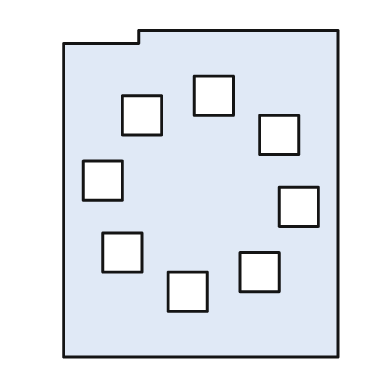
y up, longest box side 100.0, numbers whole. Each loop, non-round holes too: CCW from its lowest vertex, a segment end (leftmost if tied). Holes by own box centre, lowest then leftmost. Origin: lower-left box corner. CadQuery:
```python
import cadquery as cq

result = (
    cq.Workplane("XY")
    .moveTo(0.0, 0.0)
    .lineTo(84.0, 0.0)
    .lineTo(84.0, 100.0)
    .lineTo(23.0, 100.0)
    .lineTo(23.0, 96.0)
    .lineTo(0.0, 96.0)
    .close()
    .moveTo(32.0, 14.0)
    .lineTo(44.0, 14.0)
    .lineTo(44.0, 26.0)
    .lineTo(32.0, 26.0)
    .close()
    .moveTo(54.0, 20.0)
    .lineTo(66.0, 20.0)
    .lineTo(66.0, 32.0)
    .lineTo(54.0, 32.0)
    .close()
    .moveTo(12.0, 26.0)
    .lineTo(24.0, 26.0)
    .lineTo(24.0, 38.0)
    .lineTo(12.0, 38.0)
    .close()
    .moveTo(66.0, 40.0)
    .lineTo(78.0, 40.0)
    .lineTo(78.0, 52.0)
    .lineTo(66.0, 52.0)
    .close()
    .moveTo(6.0, 48.0)
    .lineTo(18.0, 48.0)
    .lineTo(18.0, 60.0)
    .lineTo(6.0, 60.0)
    .close()
    .moveTo(60.0, 62.0)
    .lineTo(72.0, 62.0)
    .lineTo(72.0, 74.0)
    .lineTo(60.0, 74.0)
    .close()
    .moveTo(18.0, 68.0)
    .lineTo(30.0, 68.0)
    .lineTo(30.0, 80.0)
    .lineTo(18.0, 80.0)
    .close()
    .moveTo(40.0, 74.0)
    .lineTo(52.0, 74.0)
    .lineTo(52.0, 86.0)
    .lineTo(40.0, 86.0)
    .close()
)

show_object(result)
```